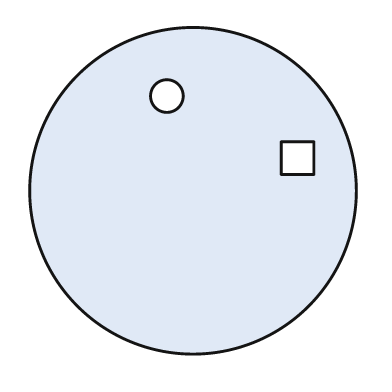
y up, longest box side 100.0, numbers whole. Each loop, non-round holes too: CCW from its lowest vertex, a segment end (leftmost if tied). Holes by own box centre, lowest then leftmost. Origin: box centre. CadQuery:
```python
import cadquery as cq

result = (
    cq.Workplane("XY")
    .moveTo(0.0, 0.0)
    .circle(50.0)
    .moveTo(27.0, 5.0)
    .lineTo(37.0, 5.0)
    .lineTo(37.0, 15.0)
    .lineTo(27.0, 15.0)
    .close()
    .moveTo(-8.0, 29.0)
    .circle(5.0)
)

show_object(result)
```